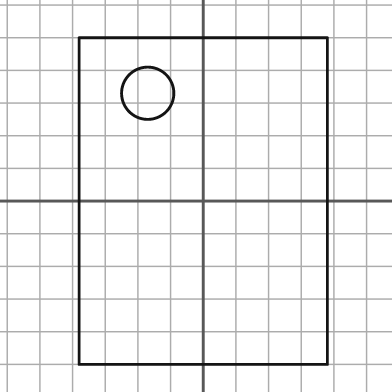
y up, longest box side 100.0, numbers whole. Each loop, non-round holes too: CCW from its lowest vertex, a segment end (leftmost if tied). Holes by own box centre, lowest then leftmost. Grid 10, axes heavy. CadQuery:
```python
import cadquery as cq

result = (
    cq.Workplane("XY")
    .moveTo(-38.0, -50.0)
    .lineTo(38.0, -50.0)
    .lineTo(38.0, 50.0)
    .lineTo(-38.0, 50.0)
    .close()
    .moveTo(-17.0, 33.0)
    .circle(8.0)
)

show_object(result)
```